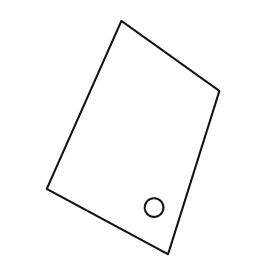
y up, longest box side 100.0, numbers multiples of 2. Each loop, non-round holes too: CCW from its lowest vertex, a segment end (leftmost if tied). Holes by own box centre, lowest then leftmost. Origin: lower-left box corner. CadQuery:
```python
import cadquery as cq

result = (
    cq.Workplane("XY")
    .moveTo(52.0, 0.0)
    .lineTo(74.0, 70.0)
    .lineTo(32.0, 100.0)
    .lineTo(0.0, 28.0)
    .close()
    .moveTo(46.0, 20.0)
    .circle(4.0)
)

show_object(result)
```